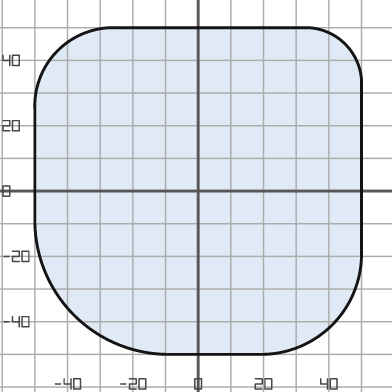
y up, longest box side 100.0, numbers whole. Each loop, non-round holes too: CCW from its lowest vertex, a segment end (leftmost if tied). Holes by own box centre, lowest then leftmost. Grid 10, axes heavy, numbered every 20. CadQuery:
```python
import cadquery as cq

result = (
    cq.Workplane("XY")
    .moveTo(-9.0, -50.0)
    .lineTo(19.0, -50.0)
    .threePointArc((41.0, -41.0), (50.0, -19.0))
    .lineTo(50.0, 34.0)
    .threePointArc((45.0, 45.0), (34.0, 50.0))
    .lineTo(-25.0, 50.0)
    .threePointArc((-43.0, 43.0), (-50.0, 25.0))
    .lineTo(-50.0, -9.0)
    .threePointArc((-38.0, -38.0), (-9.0, -50.0))
    .close()
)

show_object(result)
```